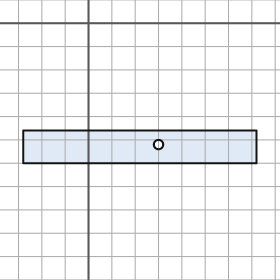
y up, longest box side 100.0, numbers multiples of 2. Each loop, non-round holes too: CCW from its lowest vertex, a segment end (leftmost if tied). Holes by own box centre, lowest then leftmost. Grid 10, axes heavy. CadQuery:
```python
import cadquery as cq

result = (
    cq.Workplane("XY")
    .moveTo(-28.0, -60.0)
    .lineTo(72.0, -60.0)
    .lineTo(72.0, -46.0)
    .lineTo(-28.0, -46.0)
    .close()
    .moveTo(30.0, -52.0)
    .circle(2.0)
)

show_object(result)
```